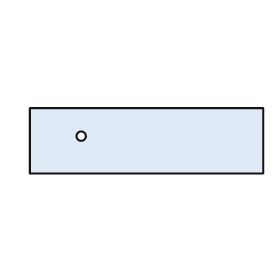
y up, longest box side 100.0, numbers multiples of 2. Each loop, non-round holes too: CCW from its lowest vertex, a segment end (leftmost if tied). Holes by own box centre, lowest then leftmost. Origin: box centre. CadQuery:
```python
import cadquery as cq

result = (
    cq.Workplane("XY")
    .moveTo(-50.0, -14.0)
    .lineTo(50.0, -14.0)
    .lineTo(50.0, 14.0)
    .lineTo(-50.0, 14.0)
    .close()
    .moveTo(-28.0, 2.0)
    .circle(2.0)
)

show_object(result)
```